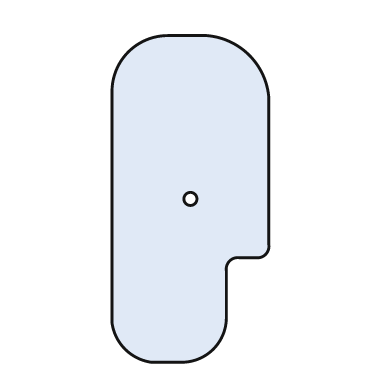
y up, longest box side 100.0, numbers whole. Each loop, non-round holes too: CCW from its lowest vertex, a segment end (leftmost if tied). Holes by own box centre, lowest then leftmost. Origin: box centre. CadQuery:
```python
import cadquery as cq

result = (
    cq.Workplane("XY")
    .moveTo(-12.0, -50.0)
    .lineTo(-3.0, -50.0)
    .threePointArc((7.0, -46.0), (11.0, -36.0))
    .lineTo(11.0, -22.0)
    .threePointArc((12.0, -19.0), (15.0, -18.0))
    .lineTo(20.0, -18.0)
    .threePointArc((23.0, -17.0), (24.0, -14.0))
    .lineTo(24.0, 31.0)
    .threePointArc((18.0, 44.0), (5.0, 50.0))
    .lineTo(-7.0, 50.0)
    .threePointArc((-19.0, 45.0), (-24.0, 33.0))
    .lineTo(-24.0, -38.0)
    .threePointArc((-20.0, -46.0), (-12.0, -50.0))
    .close()
    .moveTo(0.0, 0.0)
    .circle(2.0)
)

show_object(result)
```